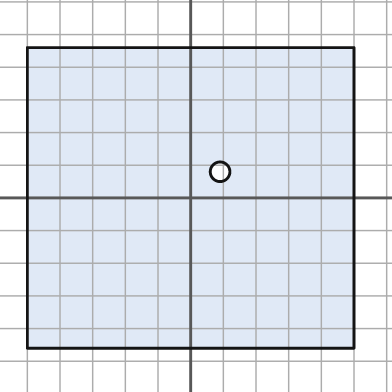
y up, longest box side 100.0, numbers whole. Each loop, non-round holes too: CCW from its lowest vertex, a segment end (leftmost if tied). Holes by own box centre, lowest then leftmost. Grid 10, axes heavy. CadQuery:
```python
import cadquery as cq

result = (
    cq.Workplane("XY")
    .moveTo(-50.0, -46.0)
    .lineTo(50.0, -46.0)
    .lineTo(50.0, 46.0)
    .lineTo(-50.0, 46.0)
    .close()
    .moveTo(9.0, 8.0)
    .circle(3.0)
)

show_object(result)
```